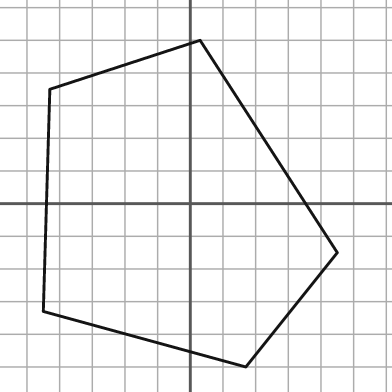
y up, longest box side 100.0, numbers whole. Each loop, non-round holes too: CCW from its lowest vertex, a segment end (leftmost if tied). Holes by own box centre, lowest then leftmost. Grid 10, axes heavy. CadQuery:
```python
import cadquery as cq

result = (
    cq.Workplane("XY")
    .moveTo(17.0, -50.0)
    .lineTo(45.0, -15.0)
    .lineTo(3.0, 50.0)
    .lineTo(-43.0, 35.0)
    .lineTo(-45.0, -33.0)
    .close()
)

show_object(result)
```